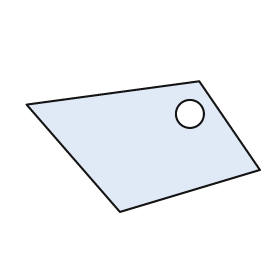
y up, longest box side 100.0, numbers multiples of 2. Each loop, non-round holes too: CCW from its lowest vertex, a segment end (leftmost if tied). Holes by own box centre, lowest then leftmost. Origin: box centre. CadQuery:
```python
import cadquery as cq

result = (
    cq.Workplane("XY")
    .moveTo(-10.0, -28.0)
    .lineTo(50.0, -10.0)
    .lineTo(24.0, 28.0)
    .lineTo(-50.0, 18.0)
    .close()
    .moveTo(20.0, 14.0)
    .circle(6.0)
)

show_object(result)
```